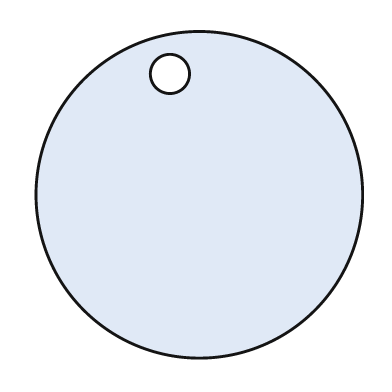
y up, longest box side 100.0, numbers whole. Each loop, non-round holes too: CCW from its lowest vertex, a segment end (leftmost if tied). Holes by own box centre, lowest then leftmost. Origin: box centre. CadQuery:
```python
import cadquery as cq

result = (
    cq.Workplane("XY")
    .moveTo(0.0, 0.0)
    .circle(50.0)
    .moveTo(-9.0, 37.0)
    .circle(6.0)
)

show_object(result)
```